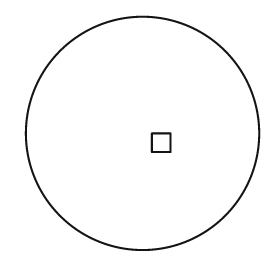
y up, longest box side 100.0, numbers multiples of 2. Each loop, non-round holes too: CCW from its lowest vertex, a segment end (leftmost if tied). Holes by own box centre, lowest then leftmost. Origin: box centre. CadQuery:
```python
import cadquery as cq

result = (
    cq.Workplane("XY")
    .moveTo(0.0, 0.0)
    .circle(50.0)
    .moveTo(4.0, -8.0)
    .lineTo(12.0, -8.0)
    .lineTo(12.0, 0.0)
    .lineTo(4.0, 0.0)
    .close()
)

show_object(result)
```